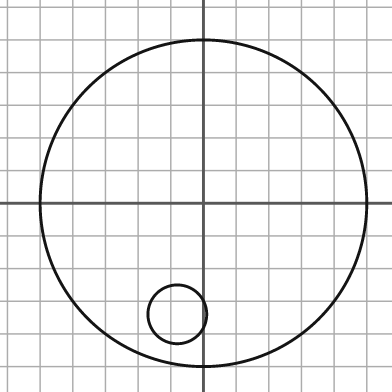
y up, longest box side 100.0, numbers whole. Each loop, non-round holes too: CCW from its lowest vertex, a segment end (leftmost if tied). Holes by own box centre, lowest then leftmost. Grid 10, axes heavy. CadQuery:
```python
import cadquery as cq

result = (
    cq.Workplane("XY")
    .moveTo(0.0, 0.0)
    .circle(50.0)
    .moveTo(-8.0, -34.0)
    .circle(9.0)
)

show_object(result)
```